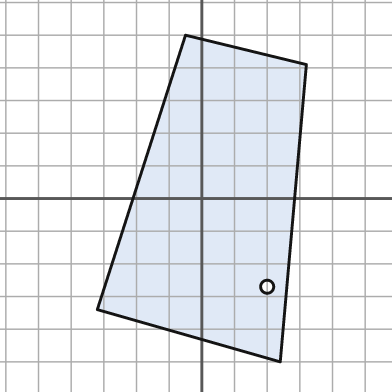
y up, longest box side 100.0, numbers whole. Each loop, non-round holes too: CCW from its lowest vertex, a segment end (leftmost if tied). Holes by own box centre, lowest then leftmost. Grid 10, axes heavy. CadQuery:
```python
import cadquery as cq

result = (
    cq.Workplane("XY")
    .moveTo(24.0, -50.0)
    .lineTo(32.0, 41.0)
    .lineTo(-5.0, 50.0)
    .lineTo(-32.0, -34.0)
    .close()
    .moveTo(20.0, -27.0)
    .circle(2.0)
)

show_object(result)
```